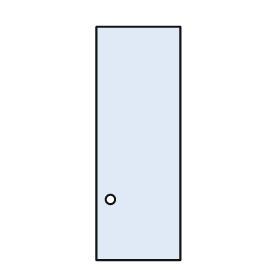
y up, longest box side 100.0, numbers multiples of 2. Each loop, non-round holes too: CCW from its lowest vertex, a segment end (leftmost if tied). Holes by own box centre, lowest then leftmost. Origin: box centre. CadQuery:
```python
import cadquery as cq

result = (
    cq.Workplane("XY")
    .moveTo(-18.0, -50.0)
    .lineTo(18.0, -50.0)
    .lineTo(18.0, 50.0)
    .lineTo(-18.0, 50.0)
    .close()
    .moveTo(-12.0, -24.0)
    .circle(2.0)
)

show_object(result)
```